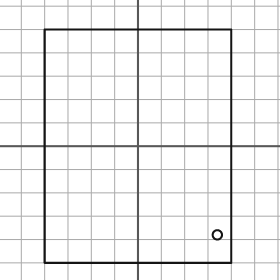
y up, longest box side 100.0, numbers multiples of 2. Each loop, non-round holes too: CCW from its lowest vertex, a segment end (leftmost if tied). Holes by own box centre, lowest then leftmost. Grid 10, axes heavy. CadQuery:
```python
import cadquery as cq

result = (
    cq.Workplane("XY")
    .moveTo(-40.0, -50.0)
    .lineTo(40.0, -50.0)
    .lineTo(40.0, 50.0)
    .lineTo(-40.0, 50.0)
    .close()
    .moveTo(34.0, -38.0)
    .circle(2.0)
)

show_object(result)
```